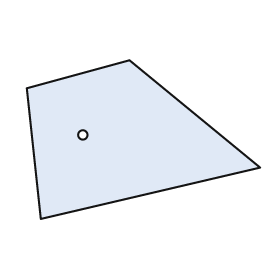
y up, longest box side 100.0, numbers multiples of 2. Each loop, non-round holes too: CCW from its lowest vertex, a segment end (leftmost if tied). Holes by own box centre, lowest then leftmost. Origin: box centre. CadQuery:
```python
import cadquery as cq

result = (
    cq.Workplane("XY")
    .moveTo(-44.0, -34.0)
    .lineTo(50.0, -12.0)
    .lineTo(-6.0, 34.0)
    .lineTo(-50.0, 22.0)
    .close()
    .moveTo(-26.0, 2.0)
    .circle(2.0)
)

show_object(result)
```